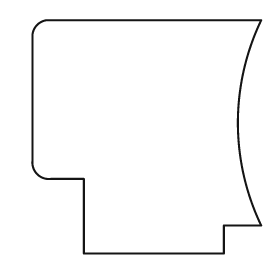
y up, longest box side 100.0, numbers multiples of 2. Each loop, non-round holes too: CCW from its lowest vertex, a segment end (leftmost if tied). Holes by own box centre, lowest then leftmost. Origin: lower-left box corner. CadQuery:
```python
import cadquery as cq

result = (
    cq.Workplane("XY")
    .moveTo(22.0, 0.0)
    .lineTo(82.0, 0.0)
    .lineTo(82.0, 12.0)
    .lineTo(98.0, 12.0)
    .threePointArc((88.0, 56.0), (98.0, 100.0))
    .lineTo(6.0, 100.0)
    .threePointArc((2.0, 98.0), (0.0, 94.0))
    .lineTo(0.0, 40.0)
    .threePointArc((2.0, 34.0), (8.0, 32.0))
    .lineTo(22.0, 32.0)
    .close()
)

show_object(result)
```